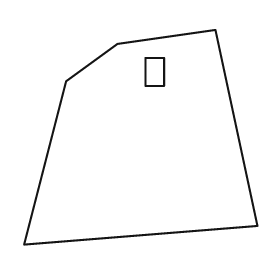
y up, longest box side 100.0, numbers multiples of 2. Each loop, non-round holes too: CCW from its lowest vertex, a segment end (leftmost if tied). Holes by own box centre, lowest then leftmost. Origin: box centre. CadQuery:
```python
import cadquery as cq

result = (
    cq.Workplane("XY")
    .moveTo(-50.0, -46.0)
    .lineTo(50.0, -38.0)
    .lineTo(32.0, 46.0)
    .lineTo(-10.0, 40.0)
    .lineTo(-32.0, 24.0)
    .close()
    .moveTo(2.0, 22.0)
    .lineTo(10.0, 22.0)
    .lineTo(10.0, 34.0)
    .lineTo(2.0, 34.0)
    .close()
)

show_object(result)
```